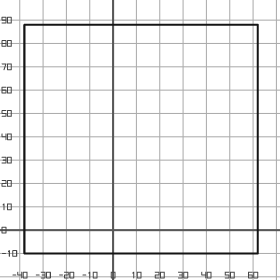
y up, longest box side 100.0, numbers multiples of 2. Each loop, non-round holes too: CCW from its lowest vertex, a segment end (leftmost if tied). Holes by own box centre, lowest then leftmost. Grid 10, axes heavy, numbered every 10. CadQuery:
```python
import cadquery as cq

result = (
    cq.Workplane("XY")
    .moveTo(-38.0, -10.0)
    .lineTo(62.0, -10.0)
    .lineTo(62.0, 88.0)
    .lineTo(-38.0, 88.0)
    .close()
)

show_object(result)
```